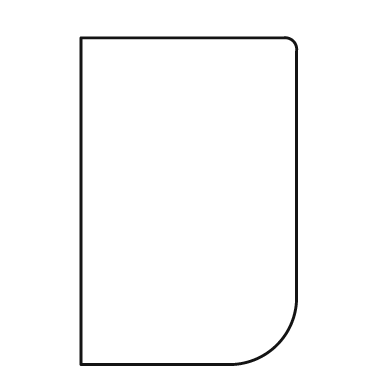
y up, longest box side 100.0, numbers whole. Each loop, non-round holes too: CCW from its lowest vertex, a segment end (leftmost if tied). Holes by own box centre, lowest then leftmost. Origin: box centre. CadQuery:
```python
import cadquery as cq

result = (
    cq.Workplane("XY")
    .moveTo(-33.0, -50.0)
    .lineTo(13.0, -50.0)
    .threePointArc((27.0, -44.0), (33.0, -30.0))
    .lineTo(33.0, 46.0)
    .threePointArc((32.0, 49.0), (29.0, 50.0))
    .lineTo(-33.0, 50.0)
    .close()
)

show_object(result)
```